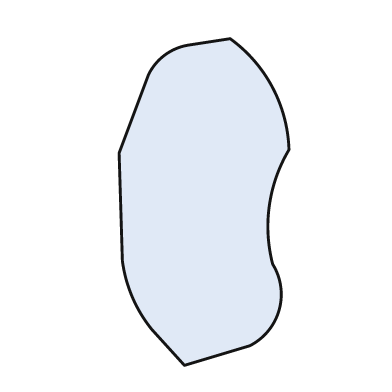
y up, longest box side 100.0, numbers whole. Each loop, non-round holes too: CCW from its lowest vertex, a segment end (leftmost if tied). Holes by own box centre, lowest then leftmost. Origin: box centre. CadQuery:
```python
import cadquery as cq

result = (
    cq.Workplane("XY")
    .moveTo(-6.0, -50.0)
    .lineTo(14.0, -44.0)
    .threePointArc((23.0, -33.0), (21.0, -19.0))
    .threePointArc((20.0, -1.0), (26.0, 16.0))
    .threePointArc((21.0, 35.0), (8.0, 50.0))
    .lineTo(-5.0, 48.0)
    .threePointArc((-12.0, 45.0), (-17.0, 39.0))
    .lineTo(-26.0, 15.0)
    .lineTo(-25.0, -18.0)
    .threePointArc((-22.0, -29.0), (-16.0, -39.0))
    .close()
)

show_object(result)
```